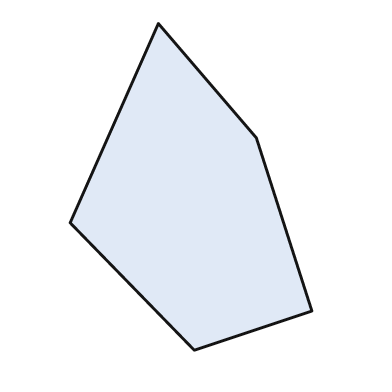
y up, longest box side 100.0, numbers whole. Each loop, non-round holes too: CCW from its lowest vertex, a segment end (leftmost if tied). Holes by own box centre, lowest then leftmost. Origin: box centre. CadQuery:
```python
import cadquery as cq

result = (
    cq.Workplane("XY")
    .moveTo(1.0, -50.0)
    .lineTo(37.0, -38.0)
    .lineTo(20.0, 15.0)
    .lineTo(-10.0, 50.0)
    .lineTo(-37.0, -11.0)
    .close()
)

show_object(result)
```